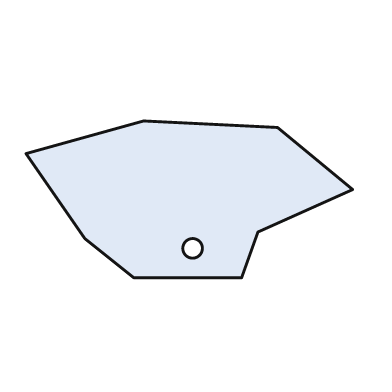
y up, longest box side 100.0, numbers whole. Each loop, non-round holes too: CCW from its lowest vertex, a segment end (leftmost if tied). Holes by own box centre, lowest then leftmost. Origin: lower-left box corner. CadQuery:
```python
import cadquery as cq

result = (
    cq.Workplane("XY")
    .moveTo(33.0, 0.0)
    .lineTo(66.0, 0.0)
    .lineTo(71.0, 14.0)
    .lineTo(100.0, 27.0)
    .lineTo(77.0, 46.0)
    .lineTo(36.0, 48.0)
    .lineTo(0.0, 38.0)
    .lineTo(18.0, 12.0)
    .close()
    .moveTo(51.0, 9.0)
    .circle(3.0)
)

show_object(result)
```